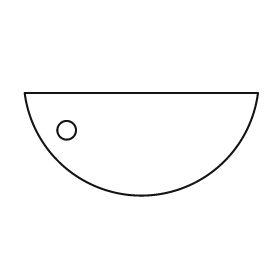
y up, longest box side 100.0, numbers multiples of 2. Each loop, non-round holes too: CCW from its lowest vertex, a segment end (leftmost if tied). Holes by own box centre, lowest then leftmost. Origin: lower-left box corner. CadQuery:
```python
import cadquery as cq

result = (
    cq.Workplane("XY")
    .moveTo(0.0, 44.0)
    .threePointArc((50.0, 0.0), (100.0, 44.0))
    .close()
    .moveTo(18.0, 28.0)
    .circle(4.0)
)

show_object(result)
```